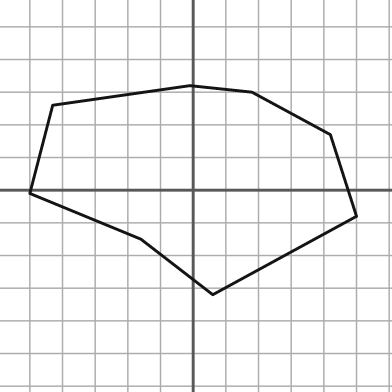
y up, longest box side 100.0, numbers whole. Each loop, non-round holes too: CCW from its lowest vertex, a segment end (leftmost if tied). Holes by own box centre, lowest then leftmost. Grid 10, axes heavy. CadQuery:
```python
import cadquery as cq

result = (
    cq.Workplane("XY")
    .moveTo(6.0, -32.0)
    .lineTo(50.0, -8.0)
    .lineTo(42.0, 17.0)
    .lineTo(18.0, 30.0)
    .lineTo(-1.0, 32.0)
    .lineTo(-43.0, 26.0)
    .lineTo(-50.0, -1.0)
    .lineTo(-16.0, -15.0)
    .close()
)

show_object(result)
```